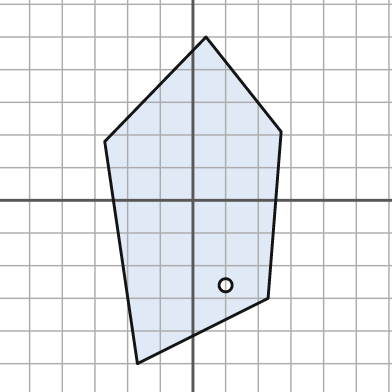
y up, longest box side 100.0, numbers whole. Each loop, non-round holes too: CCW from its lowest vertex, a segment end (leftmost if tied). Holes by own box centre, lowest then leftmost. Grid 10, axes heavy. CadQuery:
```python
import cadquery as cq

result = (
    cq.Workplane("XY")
    .moveTo(-17.0, -50.0)
    .lineTo(23.0, -30.0)
    .lineTo(27.0, 21.0)
    .lineTo(4.0, 50.0)
    .lineTo(-27.0, 18.0)
    .close()
    .moveTo(10.0, -26.0)
    .circle(2.0)
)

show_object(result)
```